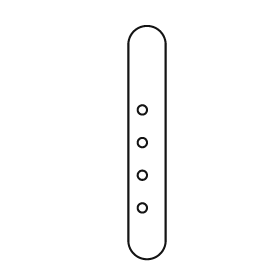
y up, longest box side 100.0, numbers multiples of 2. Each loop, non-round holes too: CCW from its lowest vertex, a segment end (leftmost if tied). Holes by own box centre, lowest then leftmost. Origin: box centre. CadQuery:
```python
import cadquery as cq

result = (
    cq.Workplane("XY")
    .moveTo(-8.0, -42.0)
    .threePointArc((0.0, -50.0), (8.0, -42.0))
    .lineTo(8.0, 42.0)
    .threePointArc((0.0, 50.0), (-8.0, 42.0))
    .close()
    .moveTo(-2.0, -28.0)
    .circle(2.0)
    .moveTo(-2.0, -14.0)
    .circle(2.0)
    .moveTo(-2.0, 0.0)
    .circle(2.0)
    .moveTo(-2.0, 14.0)
    .circle(2.0)
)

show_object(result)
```